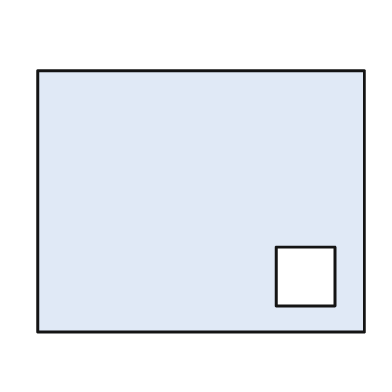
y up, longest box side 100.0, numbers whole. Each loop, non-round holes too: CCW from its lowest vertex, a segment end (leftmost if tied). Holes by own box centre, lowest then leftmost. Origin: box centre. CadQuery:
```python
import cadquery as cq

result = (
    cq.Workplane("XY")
    .moveTo(-50.0, -40.0)
    .lineTo(50.0, -40.0)
    .lineTo(50.0, 40.0)
    .lineTo(-50.0, 40.0)
    .close()
    .moveTo(23.0, -32.0)
    .lineTo(41.0, -32.0)
    .lineTo(41.0, -14.0)
    .lineTo(23.0, -14.0)
    .close()
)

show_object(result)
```